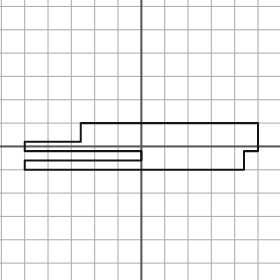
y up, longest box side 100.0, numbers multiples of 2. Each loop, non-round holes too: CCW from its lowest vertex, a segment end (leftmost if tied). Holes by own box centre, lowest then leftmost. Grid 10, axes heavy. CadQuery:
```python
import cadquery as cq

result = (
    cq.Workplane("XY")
    .moveTo(-50.0, -10.0)
    .lineTo(44.0, -10.0)
    .lineTo(44.0, -2.0)
    .lineTo(50.0, -2.0)
    .lineTo(50.0, 10.0)
    .lineTo(-26.0, 10.0)
    .lineTo(-26.0, 2.0)
    .lineTo(-50.0, 2.0)
    .lineTo(-50.0, -2.0)
    .lineTo(0.0, -2.0)
    .lineTo(0.0, -6.0)
    .lineTo(-50.0, -6.0)
    .close()
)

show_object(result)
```